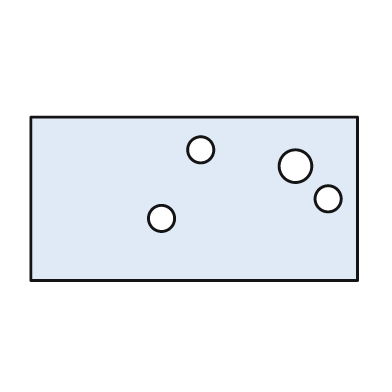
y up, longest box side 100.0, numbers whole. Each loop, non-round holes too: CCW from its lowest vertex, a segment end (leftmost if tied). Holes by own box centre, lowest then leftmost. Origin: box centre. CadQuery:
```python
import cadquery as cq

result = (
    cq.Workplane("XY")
    .moveTo(-50.0, -25.0)
    .lineTo(50.0, -25.0)
    .lineTo(50.0, 25.0)
    .lineTo(-50.0, 25.0)
    .close()
    .moveTo(-10.0, -6.0)
    .circle(4.0)
    .moveTo(41.0, 0.0)
    .circle(4.0)
    .moveTo(31.0, 10.0)
    .circle(5.0)
    .moveTo(2.0, 15.0)
    .circle(4.0)
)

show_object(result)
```